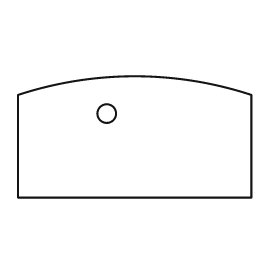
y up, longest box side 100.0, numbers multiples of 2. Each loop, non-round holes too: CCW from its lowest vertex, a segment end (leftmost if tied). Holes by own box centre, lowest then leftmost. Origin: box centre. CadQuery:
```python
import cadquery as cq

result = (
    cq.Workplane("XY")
    .moveTo(-50.0, -26.0)
    .lineTo(50.0, -26.0)
    .lineTo(50.0, 18.0)
    .threePointArc((0.0, 26.0), (-50.0, 18.0))
    .close()
    .moveTo(-12.0, 10.0)
    .circle(4.0)
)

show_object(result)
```